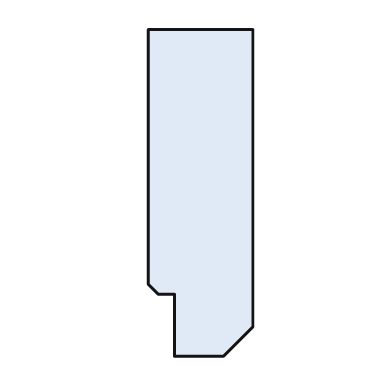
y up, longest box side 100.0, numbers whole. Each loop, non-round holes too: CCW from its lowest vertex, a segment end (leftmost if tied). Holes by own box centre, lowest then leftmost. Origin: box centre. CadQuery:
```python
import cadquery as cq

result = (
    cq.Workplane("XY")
    .moveTo(-8.0, -50.0)
    .lineTo(7.0, -50.0)
    .lineTo(16.0, -41.0)
    .lineTo(16.0, 50.0)
    .lineTo(-16.0, 50.0)
    .lineTo(-16.0, -28.0)
    .lineTo(-13.0, -31.0)
    .lineTo(-8.0, -31.0)
    .close()
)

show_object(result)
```